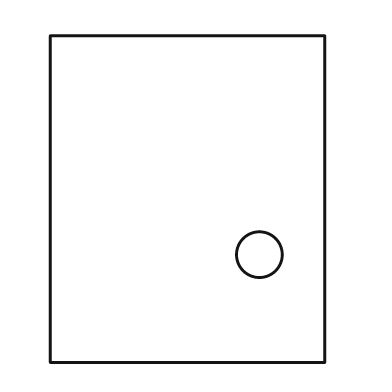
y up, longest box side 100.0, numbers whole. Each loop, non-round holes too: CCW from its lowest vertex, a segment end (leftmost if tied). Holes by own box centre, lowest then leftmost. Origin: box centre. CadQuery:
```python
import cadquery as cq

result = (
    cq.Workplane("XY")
    .moveTo(-42.0, -50.0)
    .lineTo(42.0, -50.0)
    .lineTo(42.0, 50.0)
    .lineTo(-42.0, 50.0)
    .close()
    .moveTo(22.0, -17.0)
    .circle(7.0)
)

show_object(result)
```